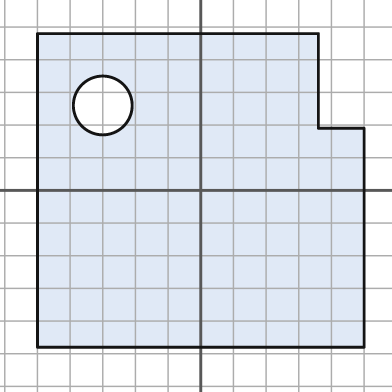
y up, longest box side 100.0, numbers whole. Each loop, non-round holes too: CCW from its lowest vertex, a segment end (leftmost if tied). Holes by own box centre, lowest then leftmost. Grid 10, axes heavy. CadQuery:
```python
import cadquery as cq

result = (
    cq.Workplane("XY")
    .moveTo(-50.0, -48.0)
    .lineTo(50.0, -48.0)
    .lineTo(50.0, 19.0)
    .lineTo(36.0, 19.0)
    .lineTo(36.0, 48.0)
    .lineTo(-50.0, 48.0)
    .close()
    .moveTo(-30.0, 26.0)
    .circle(9.0)
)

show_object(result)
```